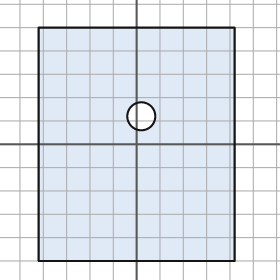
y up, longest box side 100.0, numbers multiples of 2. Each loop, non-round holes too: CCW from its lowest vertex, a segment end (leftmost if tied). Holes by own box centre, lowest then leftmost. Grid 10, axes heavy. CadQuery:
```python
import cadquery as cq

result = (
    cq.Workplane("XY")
    .moveTo(-42.0, -50.0)
    .lineTo(42.0, -50.0)
    .lineTo(42.0, 50.0)
    .lineTo(-42.0, 50.0)
    .close()
    .moveTo(2.0, 12.0)
    .circle(6.0)
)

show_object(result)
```